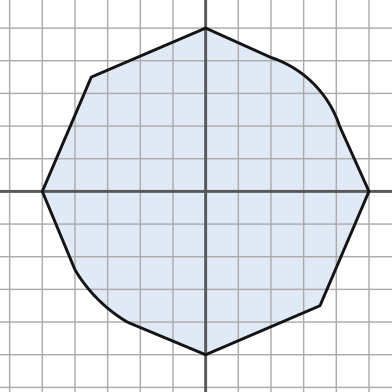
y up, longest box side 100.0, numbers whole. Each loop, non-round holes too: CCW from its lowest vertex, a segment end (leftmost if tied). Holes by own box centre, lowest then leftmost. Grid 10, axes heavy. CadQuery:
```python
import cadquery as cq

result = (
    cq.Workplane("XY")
    .moveTo(0.0, -50.0)
    .lineTo(35.0, -35.0)
    .lineTo(50.0, 0.0)
    .lineTo(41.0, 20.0)
    .threePointArc((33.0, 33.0), (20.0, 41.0))
    .lineTo(0.0, 50.0)
    .lineTo(-35.0, 35.0)
    .lineTo(-50.0, 0.0)
    .lineTo(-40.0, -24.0)
    .threePointArc((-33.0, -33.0), (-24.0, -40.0))
    .close()
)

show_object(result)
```